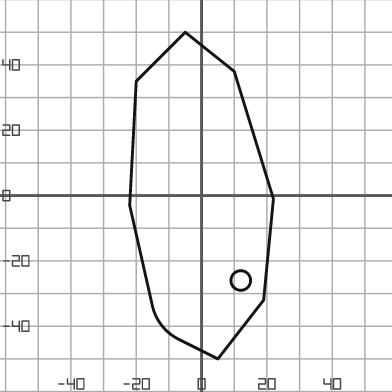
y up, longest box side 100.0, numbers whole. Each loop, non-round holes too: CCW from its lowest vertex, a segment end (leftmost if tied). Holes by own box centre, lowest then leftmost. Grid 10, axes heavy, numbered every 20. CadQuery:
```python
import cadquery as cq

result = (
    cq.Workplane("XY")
    .moveTo(5.0, -50.0)
    .lineTo(19.0, -32.0)
    .lineTo(22.0, -1.0)
    .lineTo(10.0, 38.0)
    .lineTo(-5.0, 50.0)
    .lineTo(-20.0, 35.0)
    .lineTo(-22.0, -3.0)
    .lineTo(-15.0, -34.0)
    .threePointArc((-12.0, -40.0), (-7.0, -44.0))
    .close()
    .moveTo(12.0, -26.0)
    .circle(3.0)
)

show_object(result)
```